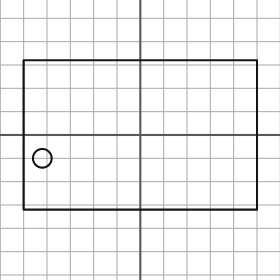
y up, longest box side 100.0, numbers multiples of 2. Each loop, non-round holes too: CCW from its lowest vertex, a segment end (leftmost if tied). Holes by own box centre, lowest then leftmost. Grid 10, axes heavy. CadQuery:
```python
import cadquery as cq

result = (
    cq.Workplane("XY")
    .moveTo(-50.0, -32.0)
    .lineTo(50.0, -32.0)
    .lineTo(50.0, 32.0)
    .lineTo(-50.0, 32.0)
    .close()
    .moveTo(-42.0, -10.0)
    .circle(4.0)
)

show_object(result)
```